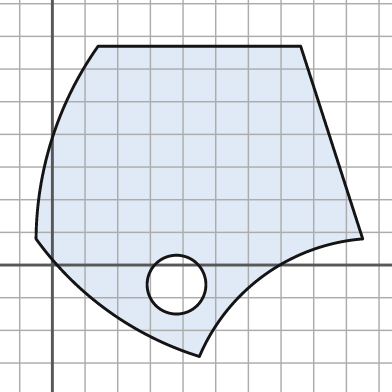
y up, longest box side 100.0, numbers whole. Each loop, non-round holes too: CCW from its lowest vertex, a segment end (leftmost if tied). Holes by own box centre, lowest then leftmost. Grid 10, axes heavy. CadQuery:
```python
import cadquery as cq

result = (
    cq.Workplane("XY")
    .moveTo(45.0, -28.0)
    .threePointArc((65.0, -3.0), (95.0, 8.0))
    .lineTo(76.0, 67.0)
    .lineTo(14.0, 67.0)
    .threePointArc((0.0, 39.0), (-5.0, 8.0))
    .threePointArc((17.0, -14.0), (45.0, -28.0))
    .close()
    .moveTo(38.0, -6.0)
    .circle(9.0)
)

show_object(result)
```